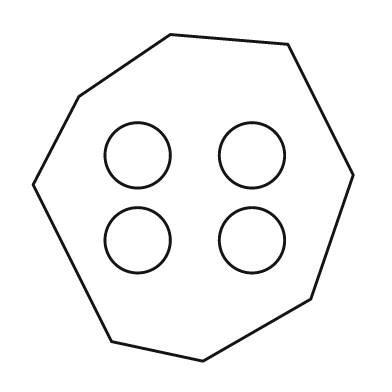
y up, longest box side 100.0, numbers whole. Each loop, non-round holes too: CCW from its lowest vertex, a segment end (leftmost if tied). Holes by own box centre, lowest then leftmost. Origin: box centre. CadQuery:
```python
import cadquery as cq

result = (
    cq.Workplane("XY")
    .moveTo(3.0, -50.0)
    .lineTo(36.0, -31.0)
    .lineTo(49.0, 7.0)
    .lineTo(29.0, 47.0)
    .lineTo(-7.0, 50.0)
    .lineTo(-35.0, 31.0)
    .lineTo(-49.0, 4.0)
    .lineTo(-25.0, -44.0)
    .close()
    .moveTo(-17.0, -13.0)
    .circle(10.0)
    .moveTo(18.0, -13.0)
    .circle(10.0)
    .moveTo(-17.0, 13.0)
    .circle(10.0)
    .moveTo(18.0, 13.0)
    .circle(10.0)
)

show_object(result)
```